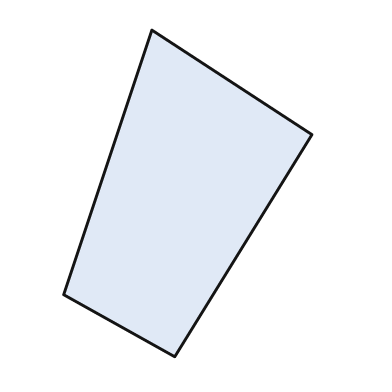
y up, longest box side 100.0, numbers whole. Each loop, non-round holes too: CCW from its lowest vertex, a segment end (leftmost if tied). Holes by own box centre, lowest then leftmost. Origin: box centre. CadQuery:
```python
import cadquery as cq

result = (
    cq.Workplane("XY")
    .moveTo(-4.0, -50.0)
    .lineTo(38.0, 18.0)
    .lineTo(-11.0, 50.0)
    .lineTo(-38.0, -31.0)
    .close()
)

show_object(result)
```